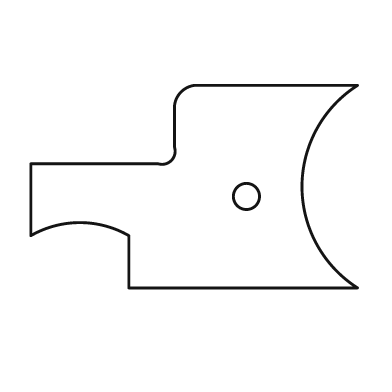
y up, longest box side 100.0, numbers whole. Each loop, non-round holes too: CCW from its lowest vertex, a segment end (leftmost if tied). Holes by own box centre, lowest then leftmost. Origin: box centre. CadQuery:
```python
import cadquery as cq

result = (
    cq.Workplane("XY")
    .moveTo(-20.0, -31.0)
    .lineTo(50.0, -31.0)
    .threePointArc((33.0, 0.0), (50.0, 31.0))
    .lineTo(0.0, 31.0)
    .threePointArc((-4.0, 29.0), (-6.0, 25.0))
    .lineTo(-6.0, 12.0)
    .threePointArc((-7.0, 8.0), (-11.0, 7.0))
    .lineTo(-50.0, 7.0)
    .lineTo(-50.0, -15.0)
    .threePointArc((-35.0, -11.0), (-20.0, -15.0))
    .close()
    .moveTo(16.0, -3.0)
    .circle(4.0)
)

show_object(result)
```